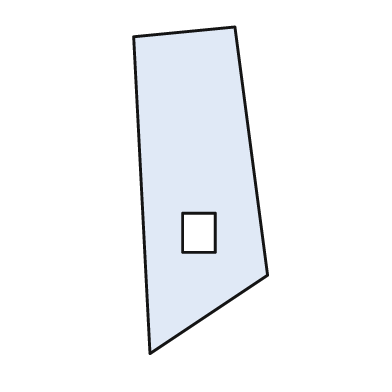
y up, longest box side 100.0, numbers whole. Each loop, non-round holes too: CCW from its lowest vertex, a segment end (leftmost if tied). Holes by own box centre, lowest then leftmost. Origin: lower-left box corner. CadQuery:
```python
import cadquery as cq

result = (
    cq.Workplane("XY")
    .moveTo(5.0, 0.0)
    .lineTo(41.0, 24.0)
    .lineTo(31.0, 100.0)
    .lineTo(0.0, 97.0)
    .close()
    .moveTo(15.0, 31.0)
    .lineTo(25.0, 31.0)
    .lineTo(25.0, 43.0)
    .lineTo(15.0, 43.0)
    .close()
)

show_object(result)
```